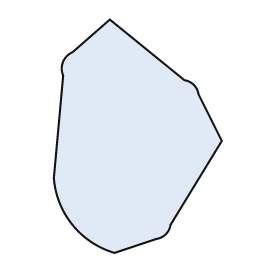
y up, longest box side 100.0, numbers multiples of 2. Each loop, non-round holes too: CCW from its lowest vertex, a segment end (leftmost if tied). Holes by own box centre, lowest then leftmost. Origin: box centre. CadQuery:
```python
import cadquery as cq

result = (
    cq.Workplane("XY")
    .moveTo(-10.0, -50.0)
    .lineTo(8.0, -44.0)
    .threePointArc((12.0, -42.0), (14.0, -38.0))
    .lineTo(36.0, -2.0)
    .lineTo(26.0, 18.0)
    .threePointArc((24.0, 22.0), (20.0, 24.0))
    .lineTo(-12.0, 50.0)
    .lineTo(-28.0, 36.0)
    .threePointArc((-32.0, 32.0), (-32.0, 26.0))
    .lineTo(-36.0, -18.0)
    .threePointArc((-28.0, -38.0), (-10.0, -50.0))
    .close()
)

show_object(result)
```